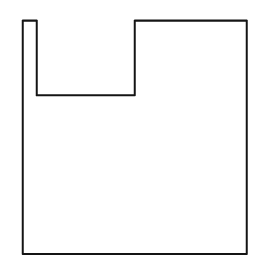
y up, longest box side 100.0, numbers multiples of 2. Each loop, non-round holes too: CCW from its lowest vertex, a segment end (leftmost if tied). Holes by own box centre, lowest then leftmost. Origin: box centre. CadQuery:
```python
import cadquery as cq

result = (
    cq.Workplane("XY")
    .moveTo(-48.0, -50.0)
    .lineTo(48.0, -50.0)
    .lineTo(48.0, 50.0)
    .lineTo(0.0, 50.0)
    .lineTo(0.0, 18.0)
    .lineTo(-42.0, 18.0)
    .lineTo(-42.0, 50.0)
    .lineTo(-48.0, 50.0)
    .close()
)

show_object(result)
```